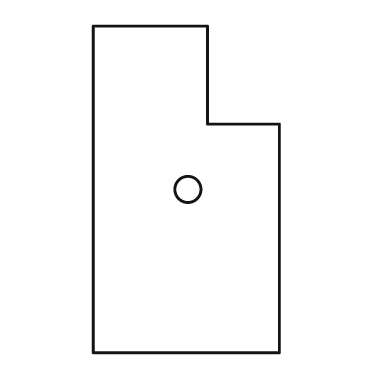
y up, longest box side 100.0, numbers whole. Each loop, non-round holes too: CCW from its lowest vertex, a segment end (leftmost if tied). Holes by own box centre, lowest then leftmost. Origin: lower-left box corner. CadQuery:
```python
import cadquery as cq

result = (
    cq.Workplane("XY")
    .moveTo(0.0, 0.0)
    .lineTo(57.0, 0.0)
    .lineTo(57.0, 70.0)
    .lineTo(35.0, 70.0)
    .lineTo(35.0, 100.0)
    .lineTo(0.0, 100.0)
    .close()
    .moveTo(29.0, 50.0)
    .circle(4.0)
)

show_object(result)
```